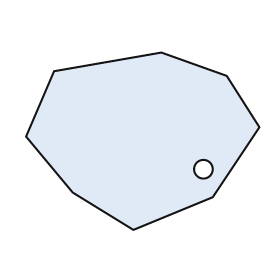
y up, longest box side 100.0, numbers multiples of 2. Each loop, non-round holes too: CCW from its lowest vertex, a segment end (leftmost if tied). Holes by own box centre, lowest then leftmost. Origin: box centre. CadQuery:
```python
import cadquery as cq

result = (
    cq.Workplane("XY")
    .moveTo(-4.0, -38.0)
    .lineTo(30.0, -24.0)
    .lineTo(50.0, 6.0)
    .lineTo(36.0, 28.0)
    .lineTo(8.0, 38.0)
    .lineTo(-38.0, 30.0)
    .lineTo(-50.0, 2.0)
    .lineTo(-30.0, -22.0)
    .close()
    .moveTo(26.0, -12.0)
    .circle(4.0)
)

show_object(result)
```